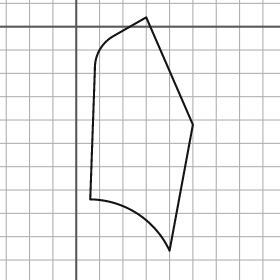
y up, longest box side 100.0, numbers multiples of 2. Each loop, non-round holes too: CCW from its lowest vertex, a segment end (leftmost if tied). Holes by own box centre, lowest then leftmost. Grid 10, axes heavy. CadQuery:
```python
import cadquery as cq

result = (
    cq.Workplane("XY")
    .moveTo(40.0, -96.0)
    .lineTo(50.0, -42.0)
    .lineTo(30.0, 4.0)
    .lineTo(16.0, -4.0)
    .threePointArc((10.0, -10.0), (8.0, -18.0))
    .lineTo(6.0, -74.0)
    .threePointArc((26.0, -80.0), (40.0, -96.0))
    .close()
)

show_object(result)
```